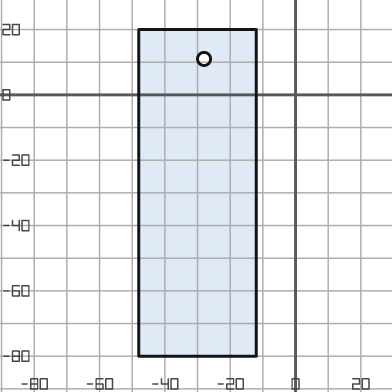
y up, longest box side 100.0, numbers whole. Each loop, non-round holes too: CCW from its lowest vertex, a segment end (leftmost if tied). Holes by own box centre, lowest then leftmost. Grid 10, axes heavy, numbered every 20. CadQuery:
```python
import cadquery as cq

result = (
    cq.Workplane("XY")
    .moveTo(-48.0, -80.0)
    .lineTo(-12.0, -80.0)
    .lineTo(-12.0, 20.0)
    .lineTo(-48.0, 20.0)
    .close()
    .moveTo(-28.0, 11.0)
    .circle(2.0)
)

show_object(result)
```